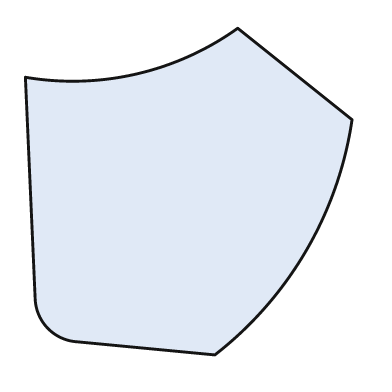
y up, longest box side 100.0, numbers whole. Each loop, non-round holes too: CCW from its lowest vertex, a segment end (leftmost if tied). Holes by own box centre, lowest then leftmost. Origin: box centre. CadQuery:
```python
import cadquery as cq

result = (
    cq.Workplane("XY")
    .moveTo(8.0, -50.0)
    .threePointArc((36.0, -18.0), (50.0, 22.0))
    .lineTo(15.0, 50.0)
    .threePointArc((-16.0, 36.0), (-50.0, 35.0))
    .lineTo(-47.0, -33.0)
    .threePointArc((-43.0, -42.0), (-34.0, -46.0))
    .close()
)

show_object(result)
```